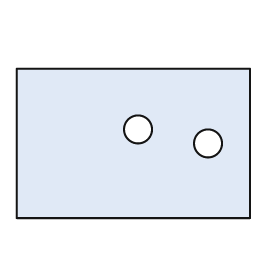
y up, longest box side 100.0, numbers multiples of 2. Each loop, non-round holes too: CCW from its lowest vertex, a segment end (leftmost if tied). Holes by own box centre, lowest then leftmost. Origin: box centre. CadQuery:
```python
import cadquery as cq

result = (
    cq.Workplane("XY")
    .moveTo(-50.0, -32.0)
    .lineTo(50.0, -32.0)
    .lineTo(50.0, 32.0)
    .lineTo(-50.0, 32.0)
    .close()
    .moveTo(32.0, 0.0)
    .circle(6.0)
    .moveTo(2.0, 6.0)
    .circle(6.0)
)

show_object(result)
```